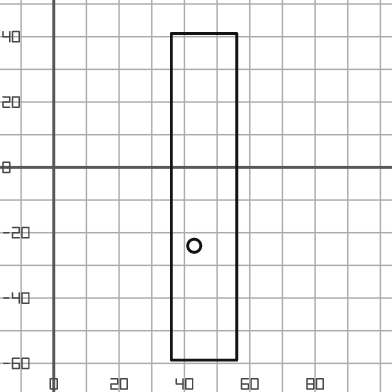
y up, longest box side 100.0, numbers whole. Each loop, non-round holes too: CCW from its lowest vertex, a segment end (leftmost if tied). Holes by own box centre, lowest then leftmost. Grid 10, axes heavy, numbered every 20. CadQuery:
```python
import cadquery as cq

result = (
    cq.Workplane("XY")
    .moveTo(36.0, -59.0)
    .lineTo(56.0, -59.0)
    .lineTo(56.0, 41.0)
    .lineTo(36.0, 41.0)
    .close()
    .moveTo(43.0, -24.0)
    .circle(2.0)
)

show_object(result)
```